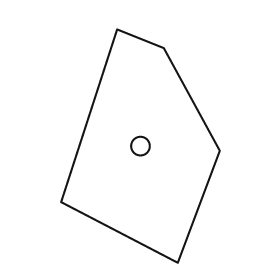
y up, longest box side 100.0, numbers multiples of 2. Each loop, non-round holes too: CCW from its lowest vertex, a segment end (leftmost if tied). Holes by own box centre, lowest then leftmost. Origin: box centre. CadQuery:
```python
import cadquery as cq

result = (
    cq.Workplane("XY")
    .moveTo(16.0, -50.0)
    .lineTo(34.0, -2.0)
    .lineTo(10.0, 42.0)
    .lineTo(-10.0, 50.0)
    .lineTo(-34.0, -24.0)
    .close()
    .moveTo(0.0, 0.0)
    .circle(4.0)
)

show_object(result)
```